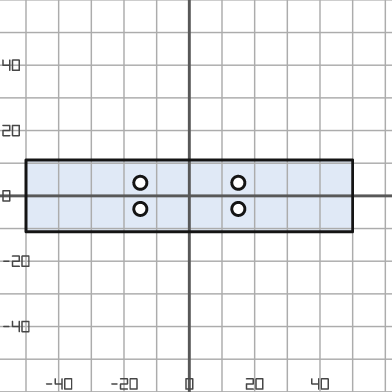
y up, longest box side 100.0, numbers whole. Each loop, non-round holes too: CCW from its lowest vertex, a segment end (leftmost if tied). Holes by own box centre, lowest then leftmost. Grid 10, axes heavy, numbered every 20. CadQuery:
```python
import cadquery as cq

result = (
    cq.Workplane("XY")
    .moveTo(-50.0, -11.0)
    .lineTo(50.0, -11.0)
    .lineTo(50.0, 11.0)
    .lineTo(-50.0, 11.0)
    .close()
    .moveTo(-15.0, -4.0)
    .circle(2.0)
    .moveTo(15.0, -4.0)
    .circle(2.0)
    .moveTo(-15.0, 4.0)
    .circle(2.0)
    .moveTo(15.0, 4.0)
    .circle(2.0)
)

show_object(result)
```